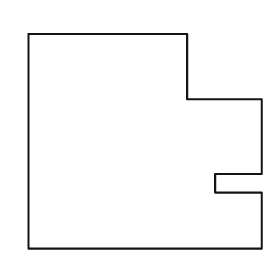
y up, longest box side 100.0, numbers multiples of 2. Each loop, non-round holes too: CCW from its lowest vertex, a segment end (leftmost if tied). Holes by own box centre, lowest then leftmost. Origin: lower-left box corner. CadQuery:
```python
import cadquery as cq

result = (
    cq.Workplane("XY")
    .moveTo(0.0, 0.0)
    .lineTo(100.0, 0.0)
    .lineTo(100.0, 24.0)
    .lineTo(80.0, 24.0)
    .lineTo(80.0, 32.0)
    .lineTo(100.0, 32.0)
    .lineTo(100.0, 64.0)
    .lineTo(68.0, 64.0)
    .lineTo(68.0, 92.0)
    .lineTo(0.0, 92.0)
    .close()
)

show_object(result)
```